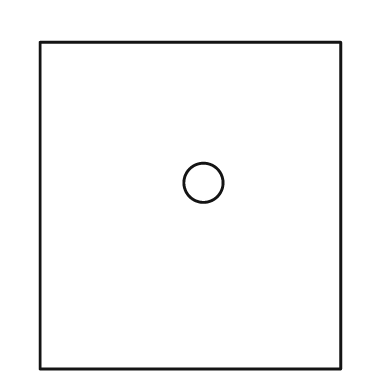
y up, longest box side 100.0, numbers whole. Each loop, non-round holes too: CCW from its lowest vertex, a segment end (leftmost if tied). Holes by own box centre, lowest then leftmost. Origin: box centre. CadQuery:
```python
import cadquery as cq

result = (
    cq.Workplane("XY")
    .moveTo(-46.0, -50.0)
    .lineTo(46.0, -50.0)
    .lineTo(46.0, 50.0)
    .lineTo(-46.0, 50.0)
    .close()
    .moveTo(4.0, 7.0)
    .circle(6.0)
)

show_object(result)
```